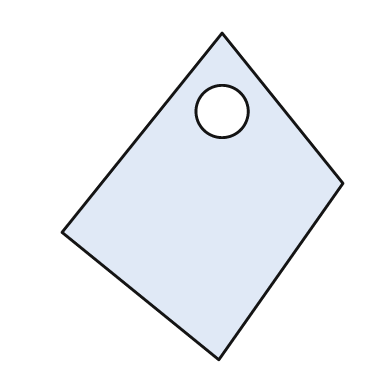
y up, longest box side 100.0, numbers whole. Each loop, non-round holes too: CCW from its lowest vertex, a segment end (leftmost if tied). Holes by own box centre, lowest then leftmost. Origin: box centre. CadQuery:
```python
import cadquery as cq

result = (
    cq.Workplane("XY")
    .moveTo(5.0, -50.0)
    .lineTo(43.0, 4.0)
    .lineTo(6.0, 50.0)
    .lineTo(-43.0, -11.0)
    .close()
    .moveTo(6.0, 26.0)
    .circle(8.0)
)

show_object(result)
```